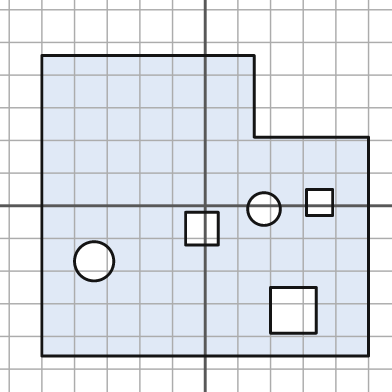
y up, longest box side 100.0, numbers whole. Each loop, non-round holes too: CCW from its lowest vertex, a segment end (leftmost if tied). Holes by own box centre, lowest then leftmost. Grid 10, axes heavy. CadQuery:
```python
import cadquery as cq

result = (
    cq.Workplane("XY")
    .moveTo(-50.0, -46.0)
    .lineTo(50.0, -46.0)
    .lineTo(50.0, 21.0)
    .lineTo(15.0, 21.0)
    .lineTo(15.0, 46.0)
    .lineTo(-50.0, 46.0)
    .close()
    .moveTo(20.0, -39.0)
    .lineTo(34.0, -39.0)
    .lineTo(34.0, -25.0)
    .lineTo(20.0, -25.0)
    .close()
    .moveTo(-34.0, -17.0)
    .circle(6.0)
    .moveTo(-6.0, -12.0)
    .lineTo(4.0, -12.0)
    .lineTo(4.0, -2.0)
    .lineTo(-6.0, -2.0)
    .close()
    .moveTo(18.0, -1.0)
    .circle(5.0)
    .moveTo(31.0, -3.0)
    .lineTo(39.0, -3.0)
    .lineTo(39.0, 5.0)
    .lineTo(31.0, 5.0)
    .close()
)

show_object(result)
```